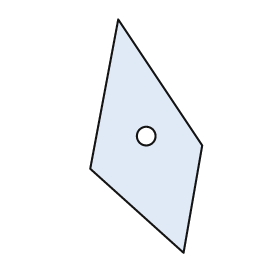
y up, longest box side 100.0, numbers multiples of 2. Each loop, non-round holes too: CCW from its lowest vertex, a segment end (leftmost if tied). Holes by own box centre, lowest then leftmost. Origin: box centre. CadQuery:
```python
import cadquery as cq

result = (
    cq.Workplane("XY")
    .moveTo(16.0, -50.0)
    .lineTo(24.0, -4.0)
    .lineTo(-12.0, 50.0)
    .lineTo(-24.0, -14.0)
    .close()
    .moveTo(0.0, 0.0)
    .circle(4.0)
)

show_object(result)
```